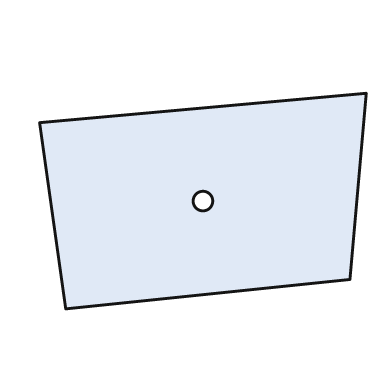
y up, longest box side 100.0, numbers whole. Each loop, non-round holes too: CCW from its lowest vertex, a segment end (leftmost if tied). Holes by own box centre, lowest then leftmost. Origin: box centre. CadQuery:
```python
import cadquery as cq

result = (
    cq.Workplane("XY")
    .moveTo(-42.0, -33.0)
    .lineTo(45.0, -24.0)
    .lineTo(50.0, 33.0)
    .lineTo(-50.0, 24.0)
    .close()
    .moveTo(0.0, 0.0)
    .circle(3.0)
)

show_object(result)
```